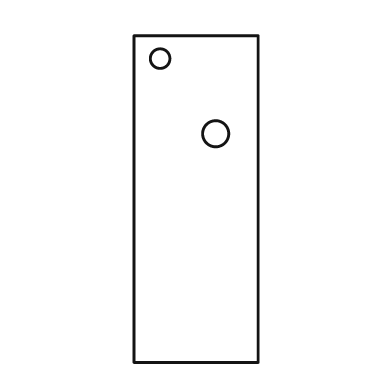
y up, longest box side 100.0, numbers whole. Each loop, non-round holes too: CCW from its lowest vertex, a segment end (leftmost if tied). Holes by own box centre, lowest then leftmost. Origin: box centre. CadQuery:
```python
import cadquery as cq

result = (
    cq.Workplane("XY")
    .moveTo(-19.0, -50.0)
    .lineTo(19.0, -50.0)
    .lineTo(19.0, 50.0)
    .lineTo(-19.0, 50.0)
    .close()
    .moveTo(6.0, 20.0)
    .circle(4.0)
    .moveTo(-11.0, 43.0)
    .circle(3.0)
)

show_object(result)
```